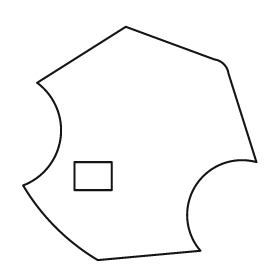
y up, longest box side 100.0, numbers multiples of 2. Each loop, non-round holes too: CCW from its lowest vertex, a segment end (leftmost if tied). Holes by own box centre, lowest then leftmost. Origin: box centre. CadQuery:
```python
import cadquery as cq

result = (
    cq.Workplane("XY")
    .moveTo(-18.0, -50.0)
    .lineTo(26.0, -46.0)
    .threePointArc((24.0, -18.0), (50.0, -8.0))
    .lineTo(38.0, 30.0)
    .threePointArc((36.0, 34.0), (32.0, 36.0))
    .lineTo(-6.0, 50.0)
    .lineTo(-44.0, 26.0)
    .threePointArc((-34.0, 2.0), (-50.0, -18.0))
    .threePointArc((-36.0, -36.0), (-18.0, -50.0))
    .close()
    .moveTo(-28.0, -20.0)
    .lineTo(-12.0, -20.0)
    .lineTo(-12.0, -8.0)
    .lineTo(-28.0, -8.0)
    .close()
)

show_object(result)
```